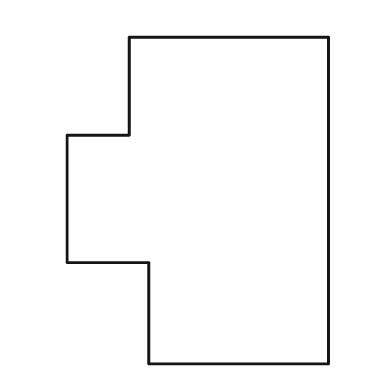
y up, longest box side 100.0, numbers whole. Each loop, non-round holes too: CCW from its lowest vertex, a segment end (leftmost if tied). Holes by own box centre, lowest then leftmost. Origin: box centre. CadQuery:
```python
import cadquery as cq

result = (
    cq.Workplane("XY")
    .moveTo(-15.0, -50.0)
    .lineTo(40.0, -50.0)
    .lineTo(40.0, 50.0)
    .lineTo(-21.0, 50.0)
    .lineTo(-21.0, 20.0)
    .lineTo(-40.0, 20.0)
    .lineTo(-40.0, -19.0)
    .lineTo(-15.0, -19.0)
    .close()
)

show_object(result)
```